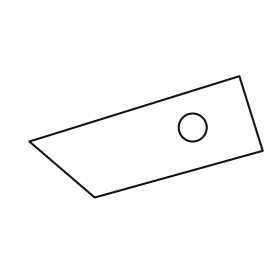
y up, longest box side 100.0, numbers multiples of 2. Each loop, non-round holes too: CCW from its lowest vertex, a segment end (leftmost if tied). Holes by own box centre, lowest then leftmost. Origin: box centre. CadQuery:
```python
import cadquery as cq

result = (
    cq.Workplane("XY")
    .moveTo(-22.0, -26.0)
    .lineTo(50.0, -6.0)
    .lineTo(40.0, 26.0)
    .lineTo(-50.0, -2.0)
    .close()
    .moveTo(20.0, 4.0)
    .circle(6.0)
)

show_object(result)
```